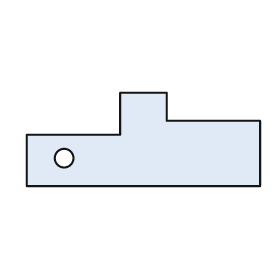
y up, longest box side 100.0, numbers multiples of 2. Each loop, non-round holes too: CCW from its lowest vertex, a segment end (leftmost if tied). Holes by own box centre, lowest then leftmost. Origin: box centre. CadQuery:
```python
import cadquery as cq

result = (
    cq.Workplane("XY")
    .moveTo(-50.0, -20.0)
    .lineTo(50.0, -20.0)
    .lineTo(50.0, 8.0)
    .lineTo(10.0, 8.0)
    .lineTo(10.0, 20.0)
    .lineTo(-10.0, 20.0)
    .lineTo(-10.0, 2.0)
    .lineTo(-50.0, 2.0)
    .close()
    .moveTo(-34.0, -8.0)
    .circle(4.0)
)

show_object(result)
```